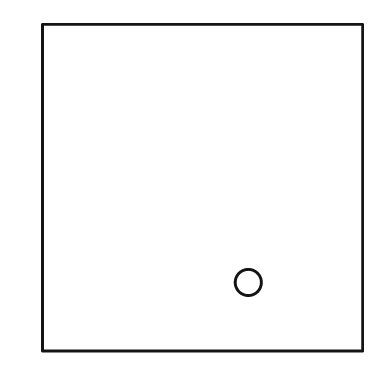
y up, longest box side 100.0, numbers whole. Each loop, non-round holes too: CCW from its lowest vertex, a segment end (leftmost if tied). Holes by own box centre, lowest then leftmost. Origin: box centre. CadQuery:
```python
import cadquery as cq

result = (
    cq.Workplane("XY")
    .moveTo(-49.0, -50.0)
    .lineTo(49.0, -50.0)
    .lineTo(49.0, 50.0)
    .lineTo(-49.0, 50.0)
    .close()
    .moveTo(14.0, -29.0)
    .circle(4.0)
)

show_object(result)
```